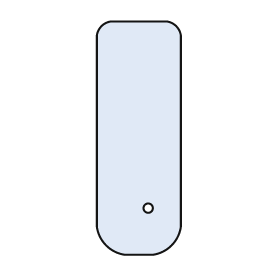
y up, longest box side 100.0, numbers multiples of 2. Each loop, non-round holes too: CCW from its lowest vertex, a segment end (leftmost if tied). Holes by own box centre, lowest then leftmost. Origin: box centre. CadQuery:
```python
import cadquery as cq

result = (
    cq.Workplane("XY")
    .moveTo(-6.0, -50.0)
    .lineTo(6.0, -50.0)
    .threePointArc((14.0, -46.0), (18.0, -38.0))
    .lineTo(18.0, 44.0)
    .threePointArc((16.0, 48.0), (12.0, 50.0))
    .lineTo(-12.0, 50.0)
    .threePointArc((-16.0, 48.0), (-18.0, 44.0))
    .lineTo(-18.0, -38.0)
    .threePointArc((-14.0, -46.0), (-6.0, -50.0))
    .close()
    .moveTo(4.0, -30.0)
    .circle(2.0)
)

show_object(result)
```